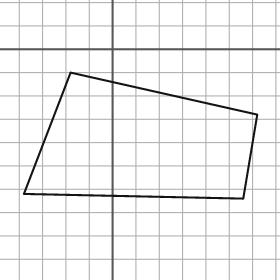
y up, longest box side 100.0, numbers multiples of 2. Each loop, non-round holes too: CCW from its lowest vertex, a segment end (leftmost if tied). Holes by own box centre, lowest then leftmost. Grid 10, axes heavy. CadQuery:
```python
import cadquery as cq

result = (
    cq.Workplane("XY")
    .moveTo(56.0, -64.0)
    .lineTo(62.0, -28.0)
    .lineTo(-18.0, -10.0)
    .lineTo(-38.0, -62.0)
    .close()
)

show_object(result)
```